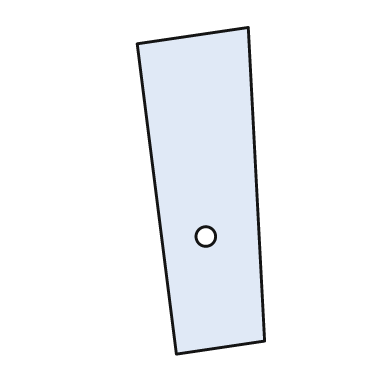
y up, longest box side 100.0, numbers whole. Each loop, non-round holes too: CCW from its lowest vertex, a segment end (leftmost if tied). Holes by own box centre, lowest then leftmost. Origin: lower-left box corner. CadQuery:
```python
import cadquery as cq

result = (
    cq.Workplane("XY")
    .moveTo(12.0, 0.0)
    .lineTo(39.0, 4.0)
    .lineTo(34.0, 100.0)
    .lineTo(0.0, 95.0)
    .close()
    .moveTo(21.0, 36.0)
    .circle(3.0)
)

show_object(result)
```